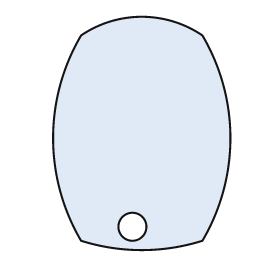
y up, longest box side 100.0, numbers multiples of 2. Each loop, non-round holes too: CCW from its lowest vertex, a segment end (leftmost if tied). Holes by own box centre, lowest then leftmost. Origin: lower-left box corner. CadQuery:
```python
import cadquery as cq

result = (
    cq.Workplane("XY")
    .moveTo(12.0, 4.0)
    .threePointArc((38.0, 0.0), (64.0, 4.0))
    .threePointArc((76.0, 48.0), (64.0, 92.0))
    .threePointArc((38.0, 100.0), (12.0, 92.0))
    .threePointArc((0.0, 48.0), (12.0, 4.0))
    .close()
    .moveTo(34.0, 10.0)
    .circle(6.0)
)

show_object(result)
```